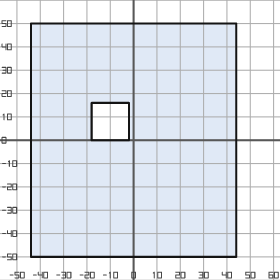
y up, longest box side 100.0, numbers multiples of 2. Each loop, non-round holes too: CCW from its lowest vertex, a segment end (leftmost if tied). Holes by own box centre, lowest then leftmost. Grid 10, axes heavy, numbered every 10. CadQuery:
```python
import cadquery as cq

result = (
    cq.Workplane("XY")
    .moveTo(-44.0, -50.0)
    .lineTo(44.0, -50.0)
    .lineTo(44.0, 50.0)
    .lineTo(-44.0, 50.0)
    .close()
    .moveTo(-18.0, 0.0)
    .lineTo(-2.0, 0.0)
    .lineTo(-2.0, 16.0)
    .lineTo(-18.0, 16.0)
    .close()
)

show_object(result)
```